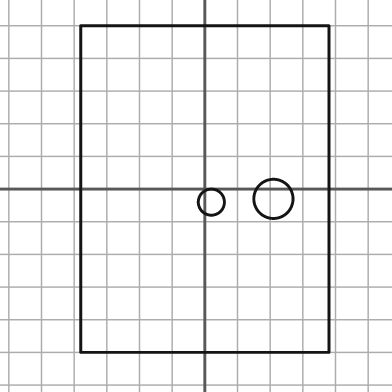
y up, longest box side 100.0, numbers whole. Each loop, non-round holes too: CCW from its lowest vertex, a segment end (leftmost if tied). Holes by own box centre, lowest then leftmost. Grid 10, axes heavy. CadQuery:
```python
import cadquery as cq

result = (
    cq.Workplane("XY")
    .moveTo(-38.0, -50.0)
    .lineTo(38.0, -50.0)
    .lineTo(38.0, 50.0)
    .lineTo(-38.0, 50.0)
    .close()
    .moveTo(2.0, -4.0)
    .circle(4.0)
    .moveTo(21.0, -3.0)
    .circle(6.0)
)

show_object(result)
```